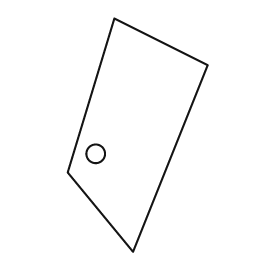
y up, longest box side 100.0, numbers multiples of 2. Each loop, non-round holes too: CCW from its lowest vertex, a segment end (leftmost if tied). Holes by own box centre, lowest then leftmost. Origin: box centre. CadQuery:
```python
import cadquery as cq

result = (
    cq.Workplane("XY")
    .moveTo(-2.0, -50.0)
    .lineTo(30.0, 30.0)
    .lineTo(-10.0, 50.0)
    .lineTo(-30.0, -16.0)
    .close()
    .moveTo(-18.0, -8.0)
    .circle(4.0)
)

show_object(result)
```